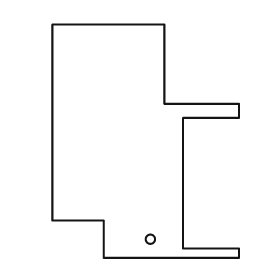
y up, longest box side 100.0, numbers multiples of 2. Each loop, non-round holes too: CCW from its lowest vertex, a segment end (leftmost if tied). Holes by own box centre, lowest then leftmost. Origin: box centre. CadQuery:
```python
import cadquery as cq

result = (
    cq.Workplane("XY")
    .moveTo(-18.0, -50.0)
    .lineTo(40.0, -50.0)
    .lineTo(40.0, -46.0)
    .lineTo(16.0, -46.0)
    .lineTo(16.0, 10.0)
    .lineTo(40.0, 10.0)
    .lineTo(40.0, 16.0)
    .lineTo(8.0, 16.0)
    .lineTo(8.0, 50.0)
    .lineTo(-40.0, 50.0)
    .lineTo(-40.0, -34.0)
    .lineTo(-18.0, -34.0)
    .close()
    .moveTo(2.0, -42.0)
    .circle(2.0)
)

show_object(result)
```